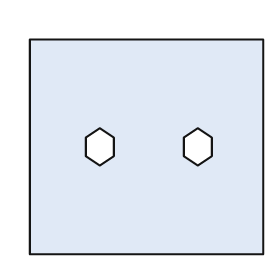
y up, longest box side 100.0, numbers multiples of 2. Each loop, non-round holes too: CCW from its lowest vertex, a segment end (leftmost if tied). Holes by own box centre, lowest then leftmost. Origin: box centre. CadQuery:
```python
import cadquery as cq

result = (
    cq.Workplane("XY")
    .moveTo(-50.0, -46.0)
    .lineTo(50.0, -46.0)
    .lineTo(50.0, 46.0)
    .lineTo(-50.0, 46.0)
    .close()
    .moveTo(-20.0, -8.0)
    .lineTo(-14.0, -4.0)
    .lineTo(-14.0, 4.0)
    .lineTo(-20.0, 8.0)
    .lineTo(-26.0, 4.0)
    .lineTo(-26.0, -4.0)
    .close()
    .moveTo(22.0, -8.0)
    .lineTo(28.0, -4.0)
    .lineTo(28.0, 4.0)
    .lineTo(22.0, 8.0)
    .lineTo(16.0, 4.0)
    .lineTo(16.0, -4.0)
    .close()
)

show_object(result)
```